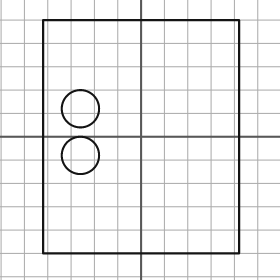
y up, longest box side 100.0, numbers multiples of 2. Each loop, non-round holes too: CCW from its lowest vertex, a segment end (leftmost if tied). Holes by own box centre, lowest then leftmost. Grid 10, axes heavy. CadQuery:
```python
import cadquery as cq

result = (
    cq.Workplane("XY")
    .moveTo(-42.0, -50.0)
    .lineTo(42.0, -50.0)
    .lineTo(42.0, 50.0)
    .lineTo(-42.0, 50.0)
    .close()
    .moveTo(-26.0, -8.0)
    .circle(8.0)
    .moveTo(-26.0, 12.0)
    .circle(8.0)
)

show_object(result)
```